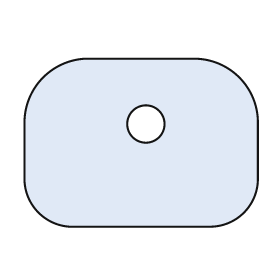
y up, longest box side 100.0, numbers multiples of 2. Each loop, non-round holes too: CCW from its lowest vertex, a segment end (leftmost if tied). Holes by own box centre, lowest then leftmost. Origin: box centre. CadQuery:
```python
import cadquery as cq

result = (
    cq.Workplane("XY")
    .moveTo(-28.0, -36.0)
    .lineTo(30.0, -36.0)
    .threePointArc((44.0, -30.0), (50.0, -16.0))
    .lineTo(50.0, 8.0)
    .threePointArc((42.0, 28.0), (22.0, 36.0))
    .lineTo(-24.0, 36.0)
    .threePointArc((-42.0, 28.0), (-50.0, 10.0))
    .lineTo(-50.0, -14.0)
    .threePointArc((-44.0, -30.0), (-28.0, -36.0))
    .close()
    .moveTo(2.0, 8.0)
    .circle(8.0)
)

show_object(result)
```